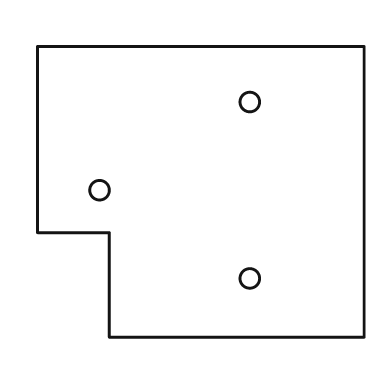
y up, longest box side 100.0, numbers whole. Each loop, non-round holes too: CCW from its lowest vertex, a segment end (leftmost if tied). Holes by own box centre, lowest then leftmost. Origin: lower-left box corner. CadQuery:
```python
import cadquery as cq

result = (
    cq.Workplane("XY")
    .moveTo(22.0, 0.0)
    .lineTo(100.0, 0.0)
    .lineTo(100.0, 89.0)
    .lineTo(0.0, 89.0)
    .lineTo(0.0, 32.0)
    .lineTo(22.0, 32.0)
    .close()
    .moveTo(65.0, 18.0)
    .circle(3.0)
    .moveTo(19.0, 45.0)
    .circle(3.0)
    .moveTo(65.0, 72.0)
    .circle(3.0)
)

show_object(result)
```